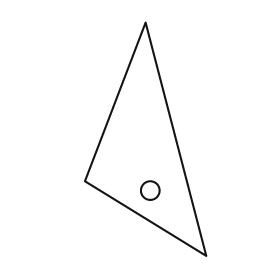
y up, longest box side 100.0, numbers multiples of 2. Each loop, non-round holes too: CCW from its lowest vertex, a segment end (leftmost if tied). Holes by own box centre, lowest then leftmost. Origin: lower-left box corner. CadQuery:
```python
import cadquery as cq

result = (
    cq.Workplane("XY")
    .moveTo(52.0, 0.0)
    .lineTo(26.0, 100.0)
    .lineTo(0.0, 32.0)
    .close()
    .moveTo(28.0, 28.0)
    .circle(4.0)
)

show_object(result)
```